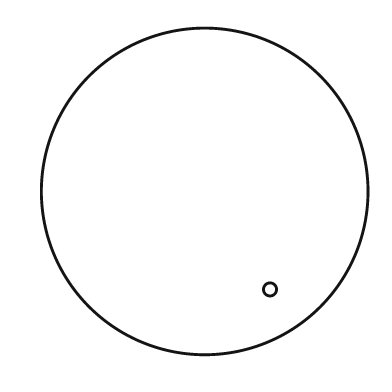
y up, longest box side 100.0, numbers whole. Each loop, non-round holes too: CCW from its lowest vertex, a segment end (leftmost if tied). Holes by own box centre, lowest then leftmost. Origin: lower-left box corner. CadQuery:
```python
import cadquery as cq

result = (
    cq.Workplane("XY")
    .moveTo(50.0, 50.0)
    .circle(50.0)
    .moveTo(70.0, 20.0)
    .circle(2.0)
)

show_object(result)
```